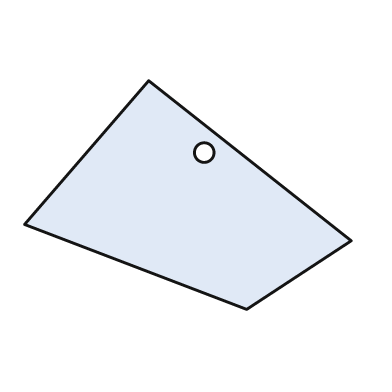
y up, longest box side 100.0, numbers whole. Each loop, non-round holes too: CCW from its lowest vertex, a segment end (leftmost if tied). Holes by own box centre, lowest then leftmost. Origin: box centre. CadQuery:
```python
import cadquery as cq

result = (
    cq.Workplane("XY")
    .moveTo(18.0, -35.0)
    .lineTo(50.0, -14.0)
    .lineTo(-12.0, 35.0)
    .lineTo(-50.0, -9.0)
    .close()
    .moveTo(5.0, 13.0)
    .circle(3.0)
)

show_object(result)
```